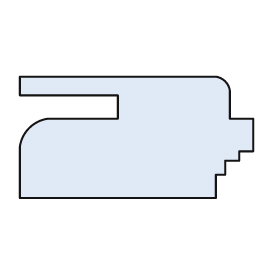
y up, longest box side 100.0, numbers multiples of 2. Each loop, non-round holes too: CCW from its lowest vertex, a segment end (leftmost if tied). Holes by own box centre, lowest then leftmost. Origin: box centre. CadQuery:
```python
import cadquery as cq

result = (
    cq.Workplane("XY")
    .moveTo(-50.0, -26.0)
    .lineTo(34.0, -26.0)
    .lineTo(34.0, -16.0)
    .lineTo(38.0, -16.0)
    .lineTo(38.0, -10.0)
    .lineTo(44.0, -10.0)
    .lineTo(44.0, -6.0)
    .lineTo(50.0, -6.0)
    .lineTo(50.0, 8.0)
    .lineTo(40.0, 8.0)
    .lineTo(40.0, 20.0)
    .threePointArc((38.0, 24.0), (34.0, 26.0))
    .lineTo(-50.0, 26.0)
    .lineTo(-50.0, 18.0)
    .lineTo(-8.0, 18.0)
    .lineTo(-8.0, 8.0)
    .lineTo(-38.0, 8.0)
    .threePointArc((-46.0, 4.0), (-50.0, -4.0))
    .close()
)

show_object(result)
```